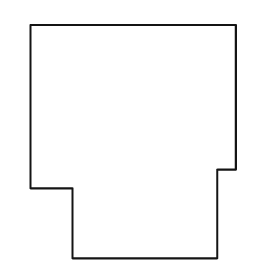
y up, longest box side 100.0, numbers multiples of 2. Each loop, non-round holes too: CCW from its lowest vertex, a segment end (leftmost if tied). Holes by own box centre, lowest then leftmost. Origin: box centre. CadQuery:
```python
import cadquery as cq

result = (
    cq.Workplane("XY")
    .moveTo(-26.0, -50.0)
    .lineTo(36.0, -50.0)
    .lineTo(36.0, -12.0)
    .lineTo(44.0, -12.0)
    .lineTo(44.0, 50.0)
    .lineTo(-44.0, 50.0)
    .lineTo(-44.0, -20.0)
    .lineTo(-26.0, -20.0)
    .close()
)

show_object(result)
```